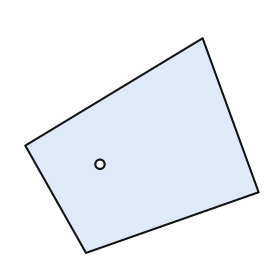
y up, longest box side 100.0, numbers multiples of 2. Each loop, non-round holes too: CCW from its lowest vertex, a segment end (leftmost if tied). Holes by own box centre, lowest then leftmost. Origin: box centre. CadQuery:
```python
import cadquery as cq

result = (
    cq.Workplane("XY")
    .moveTo(-24.0, -46.0)
    .lineTo(50.0, -20.0)
    .lineTo(26.0, 46.0)
    .lineTo(-50.0, 0.0)
    .close()
    .moveTo(-18.0, -8.0)
    .circle(2.0)
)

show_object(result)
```